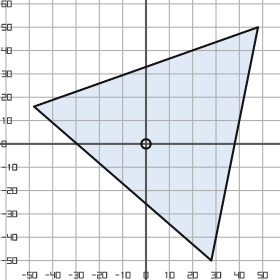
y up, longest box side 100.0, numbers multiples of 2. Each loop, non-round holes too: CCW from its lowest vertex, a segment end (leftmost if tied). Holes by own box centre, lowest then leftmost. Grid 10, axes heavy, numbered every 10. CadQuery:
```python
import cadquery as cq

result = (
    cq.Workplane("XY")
    .moveTo(28.0, -50.0)
    .lineTo(48.0, 50.0)
    .lineTo(-48.0, 16.0)
    .close()
    .moveTo(0.0, 0.0)
    .circle(2.0)
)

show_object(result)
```